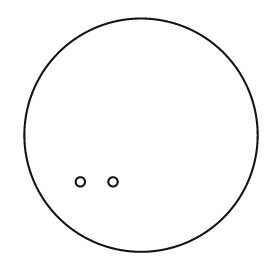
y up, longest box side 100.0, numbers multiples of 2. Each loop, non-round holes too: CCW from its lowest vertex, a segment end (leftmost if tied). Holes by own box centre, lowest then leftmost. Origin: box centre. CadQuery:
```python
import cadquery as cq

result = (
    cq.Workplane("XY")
    .moveTo(0.0, 0.0)
    .circle(50.0)
    .moveTo(-26.0, -20.0)
    .circle(2.0)
    .moveTo(-12.0, -20.0)
    .circle(2.0)
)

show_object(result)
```